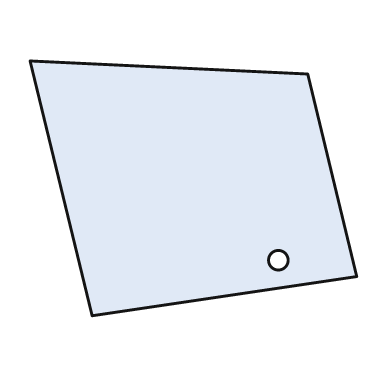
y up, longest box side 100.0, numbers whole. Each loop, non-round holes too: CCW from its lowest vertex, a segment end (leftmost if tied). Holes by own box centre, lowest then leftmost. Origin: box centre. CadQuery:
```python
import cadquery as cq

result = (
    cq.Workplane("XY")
    .moveTo(-31.0, -39.0)
    .lineTo(50.0, -27.0)
    .lineTo(35.0, 35.0)
    .lineTo(-50.0, 39.0)
    .close()
    .moveTo(26.0, -22.0)
    .circle(3.0)
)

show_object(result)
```